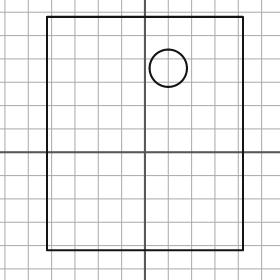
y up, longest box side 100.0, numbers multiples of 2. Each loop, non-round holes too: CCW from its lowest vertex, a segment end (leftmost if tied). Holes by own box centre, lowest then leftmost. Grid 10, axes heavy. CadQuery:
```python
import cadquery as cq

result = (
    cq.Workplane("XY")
    .moveTo(-42.0, -42.0)
    .lineTo(42.0, -42.0)
    .lineTo(42.0, 58.0)
    .lineTo(-42.0, 58.0)
    .close()
    .moveTo(10.0, 36.0)
    .circle(8.0)
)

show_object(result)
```